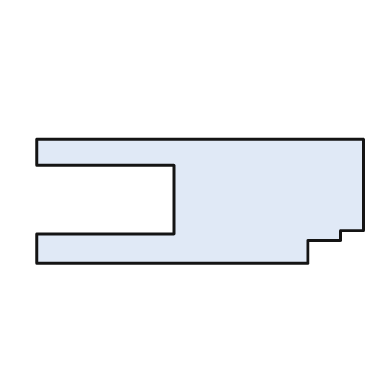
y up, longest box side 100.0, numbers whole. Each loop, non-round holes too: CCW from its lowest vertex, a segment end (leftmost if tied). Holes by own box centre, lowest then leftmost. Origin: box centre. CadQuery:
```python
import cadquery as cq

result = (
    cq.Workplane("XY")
    .moveTo(-50.0, -19.0)
    .lineTo(33.0, -19.0)
    .lineTo(33.0, -12.0)
    .lineTo(43.0, -12.0)
    .lineTo(43.0, -9.0)
    .lineTo(50.0, -9.0)
    .lineTo(50.0, 19.0)
    .lineTo(-50.0, 19.0)
    .lineTo(-50.0, 11.0)
    .lineTo(-8.0, 11.0)
    .lineTo(-8.0, -10.0)
    .lineTo(-50.0, -10.0)
    .close()
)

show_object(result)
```